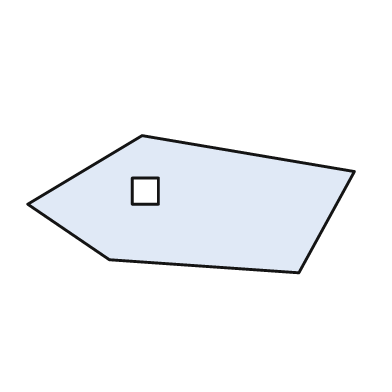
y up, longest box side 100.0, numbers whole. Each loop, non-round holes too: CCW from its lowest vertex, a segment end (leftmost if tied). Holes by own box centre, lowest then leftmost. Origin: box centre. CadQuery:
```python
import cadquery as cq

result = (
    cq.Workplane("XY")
    .moveTo(33.0, -21.0)
    .lineTo(50.0, 10.0)
    .lineTo(-15.0, 21.0)
    .lineTo(-50.0, 0.0)
    .lineTo(-25.0, -17.0)
    .close()
    .moveTo(-18.0, 0.0)
    .lineTo(-10.0, 0.0)
    .lineTo(-10.0, 8.0)
    .lineTo(-18.0, 8.0)
    .close()
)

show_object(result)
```